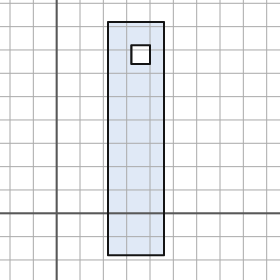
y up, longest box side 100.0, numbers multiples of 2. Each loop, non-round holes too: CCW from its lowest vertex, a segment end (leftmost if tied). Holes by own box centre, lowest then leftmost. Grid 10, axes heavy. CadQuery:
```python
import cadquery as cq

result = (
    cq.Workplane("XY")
    .moveTo(22.0, -18.0)
    .lineTo(46.0, -18.0)
    .lineTo(46.0, 82.0)
    .lineTo(22.0, 82.0)
    .close()
    .moveTo(32.0, 64.0)
    .lineTo(40.0, 64.0)
    .lineTo(40.0, 72.0)
    .lineTo(32.0, 72.0)
    .close()
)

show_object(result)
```